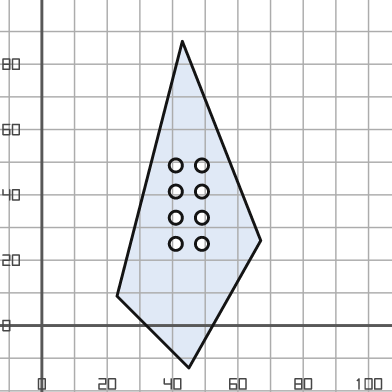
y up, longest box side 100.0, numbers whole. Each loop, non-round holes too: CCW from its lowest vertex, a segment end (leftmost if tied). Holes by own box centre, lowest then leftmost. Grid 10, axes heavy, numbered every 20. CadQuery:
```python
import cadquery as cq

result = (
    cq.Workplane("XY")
    .moveTo(45.0, -13.0)
    .lineTo(67.0, 26.0)
    .lineTo(43.0, 87.0)
    .lineTo(23.0, 9.0)
    .close()
    .moveTo(41.0, 25.0)
    .circle(2.0)
    .moveTo(49.0, 25.0)
    .circle(2.0)
    .moveTo(41.0, 33.0)
    .circle(2.0)
    .moveTo(49.0, 33.0)
    .circle(2.0)
    .moveTo(41.0, 41.0)
    .circle(2.0)
    .moveTo(49.0, 41.0)
    .circle(2.0)
    .moveTo(41.0, 49.0)
    .circle(2.0)
    .moveTo(49.0, 49.0)
    .circle(2.0)
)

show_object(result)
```